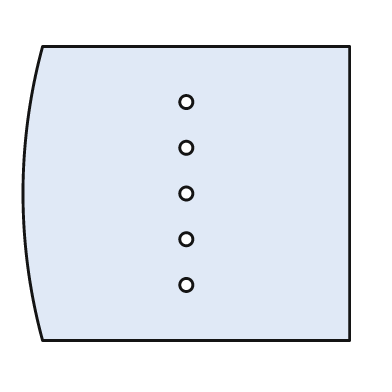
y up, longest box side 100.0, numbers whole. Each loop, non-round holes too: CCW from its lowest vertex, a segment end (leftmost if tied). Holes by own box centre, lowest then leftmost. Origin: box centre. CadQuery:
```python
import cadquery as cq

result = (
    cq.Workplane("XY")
    .moveTo(-44.0, -45.0)
    .lineTo(50.0, -45.0)
    .lineTo(50.0, 45.0)
    .lineTo(-44.0, 45.0)
    .threePointArc((-50.0, 0.0), (-44.0, -45.0))
    .close()
    .moveTo(0.0, -28.0)
    .circle(2.0)
    .moveTo(0.0, -14.0)
    .circle(2.0)
    .moveTo(0.0, 0.0)
    .circle(2.0)
    .moveTo(0.0, 14.0)
    .circle(2.0)
    .moveTo(0.0, 28.0)
    .circle(2.0)
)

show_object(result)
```